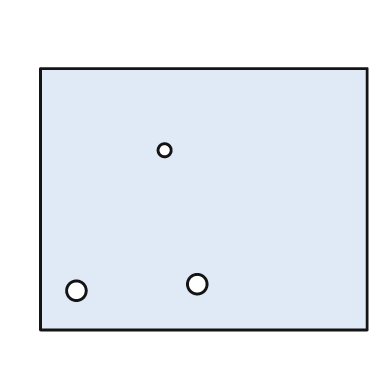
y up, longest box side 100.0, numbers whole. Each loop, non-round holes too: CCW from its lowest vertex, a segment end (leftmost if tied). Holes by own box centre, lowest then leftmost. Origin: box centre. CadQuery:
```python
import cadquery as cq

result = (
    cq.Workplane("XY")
    .moveTo(-50.0, -40.0)
    .lineTo(50.0, -40.0)
    .lineTo(50.0, 40.0)
    .lineTo(-50.0, 40.0)
    .close()
    .moveTo(-39.0, -28.0)
    .circle(3.0)
    .moveTo(-2.0, -26.0)
    .circle(3.0)
    .moveTo(-12.0, 15.0)
    .circle(2.0)
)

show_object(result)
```